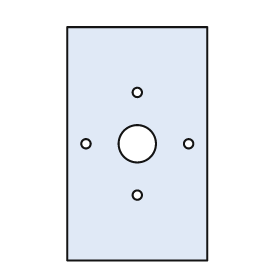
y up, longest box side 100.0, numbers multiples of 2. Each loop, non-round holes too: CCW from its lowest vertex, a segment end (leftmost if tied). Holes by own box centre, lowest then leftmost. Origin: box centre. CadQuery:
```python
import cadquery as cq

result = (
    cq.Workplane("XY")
    .moveTo(-30.0, -50.0)
    .lineTo(30.0, -50.0)
    .lineTo(30.0, 50.0)
    .lineTo(-30.0, 50.0)
    .close()
    .moveTo(0.0, -22.0)
    .circle(2.0)
    .moveTo(-22.0, 0.0)
    .circle(2.0)
    .moveTo(0.0, 0.0)
    .circle(8.0)
    .moveTo(22.0, 0.0)
    .circle(2.0)
    .moveTo(0.0, 22.0)
    .circle(2.0)
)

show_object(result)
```